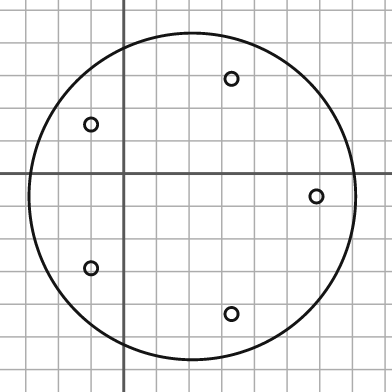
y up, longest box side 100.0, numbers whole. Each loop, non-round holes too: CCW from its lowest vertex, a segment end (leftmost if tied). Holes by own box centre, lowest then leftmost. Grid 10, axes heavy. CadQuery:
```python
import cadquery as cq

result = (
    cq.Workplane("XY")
    .moveTo(21.0, -7.0)
    .circle(50.0)
    .moveTo(33.0, -43.0)
    .circle(2.0)
    .moveTo(-10.0, -29.0)
    .circle(2.0)
    .moveTo(59.0, -7.0)
    .circle(2.0)
    .moveTo(-10.0, 15.0)
    .circle(2.0)
    .moveTo(33.0, 29.0)
    .circle(2.0)
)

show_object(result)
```